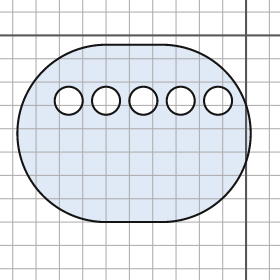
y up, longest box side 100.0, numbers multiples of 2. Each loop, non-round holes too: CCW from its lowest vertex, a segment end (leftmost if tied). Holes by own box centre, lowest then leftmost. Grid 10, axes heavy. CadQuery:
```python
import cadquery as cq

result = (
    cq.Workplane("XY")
    .moveTo(-60.0, -80.0)
    .lineTo(-36.0, -80.0)
    .threePointArc((2.0, -42.0), (-36.0, -4.0))
    .lineTo(-60.0, -4.0)
    .threePointArc((-98.0, -42.0), (-60.0, -80.0))
    .close()
    .moveTo(-76.0, -28.0)
    .circle(6.0)
    .moveTo(-60.0, -28.0)
    .circle(6.0)
    .moveTo(-44.0, -28.0)
    .circle(6.0)
    .moveTo(-28.0, -28.0)
    .circle(6.0)
    .moveTo(-12.0, -28.0)
    .circle(6.0)
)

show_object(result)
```